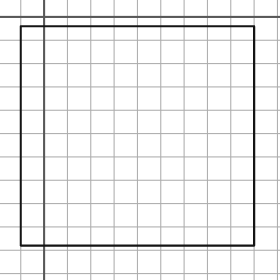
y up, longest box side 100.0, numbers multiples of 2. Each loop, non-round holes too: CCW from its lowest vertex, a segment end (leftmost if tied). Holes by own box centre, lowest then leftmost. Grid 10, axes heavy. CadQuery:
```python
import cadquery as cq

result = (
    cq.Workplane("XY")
    .moveTo(-10.0, -98.0)
    .lineTo(90.0, -98.0)
    .lineTo(90.0, -4.0)
    .lineTo(-10.0, -4.0)
    .close()
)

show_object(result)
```